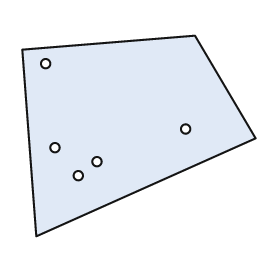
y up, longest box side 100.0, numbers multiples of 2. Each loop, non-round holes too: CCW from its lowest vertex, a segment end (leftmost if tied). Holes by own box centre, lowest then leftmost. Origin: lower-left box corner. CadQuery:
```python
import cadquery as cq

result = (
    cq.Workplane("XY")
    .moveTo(6.0, 0.0)
    .lineTo(100.0, 42.0)
    .lineTo(74.0, 86.0)
    .lineTo(0.0, 80.0)
    .close()
    .moveTo(24.0, 26.0)
    .circle(2.0)
    .moveTo(32.0, 32.0)
    .circle(2.0)
    .moveTo(14.0, 38.0)
    .circle(2.0)
    .moveTo(70.0, 46.0)
    .circle(2.0)
    .moveTo(10.0, 74.0)
    .circle(2.0)
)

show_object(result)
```